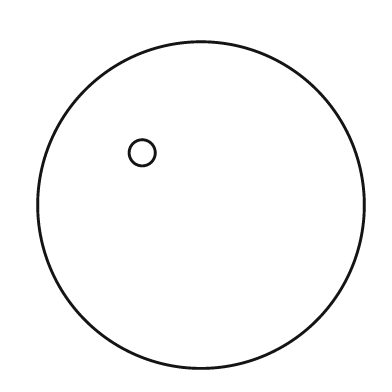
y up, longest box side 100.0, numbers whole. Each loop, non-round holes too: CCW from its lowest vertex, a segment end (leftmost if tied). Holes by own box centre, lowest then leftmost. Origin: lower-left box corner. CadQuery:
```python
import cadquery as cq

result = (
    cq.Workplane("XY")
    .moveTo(50.0, 50.0)
    .circle(50.0)
    .moveTo(32.0, 66.0)
    .circle(4.0)
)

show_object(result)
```